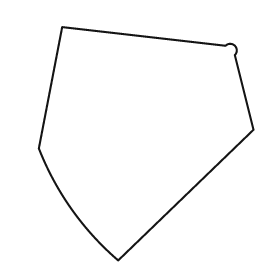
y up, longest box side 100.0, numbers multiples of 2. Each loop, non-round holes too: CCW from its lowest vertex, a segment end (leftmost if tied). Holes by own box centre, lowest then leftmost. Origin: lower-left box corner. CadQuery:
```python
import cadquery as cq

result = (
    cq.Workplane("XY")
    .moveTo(34.0, 0.0)
    .lineTo(92.0, 56.0)
    .lineTo(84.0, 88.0)
    .threePointArc((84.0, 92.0), (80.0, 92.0))
    .lineTo(10.0, 100.0)
    .lineTo(0.0, 48.0)
    .threePointArc((14.0, 22.0), (34.0, 0.0))
    .close()
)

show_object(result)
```